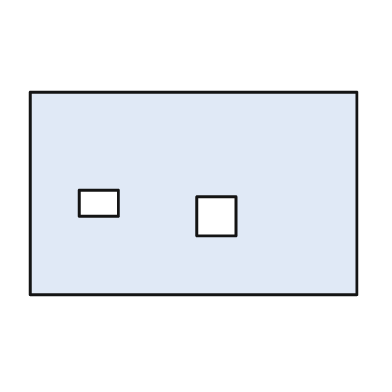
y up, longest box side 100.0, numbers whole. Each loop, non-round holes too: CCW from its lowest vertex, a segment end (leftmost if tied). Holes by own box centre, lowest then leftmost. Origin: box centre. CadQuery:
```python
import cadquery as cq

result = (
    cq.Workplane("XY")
    .moveTo(-50.0, -31.0)
    .lineTo(50.0, -31.0)
    .lineTo(50.0, 31.0)
    .lineTo(-50.0, 31.0)
    .close()
    .moveTo(1.0, -13.0)
    .lineTo(13.0, -13.0)
    .lineTo(13.0, -1.0)
    .lineTo(1.0, -1.0)
    .close()
    .moveTo(-35.0, -7.0)
    .lineTo(-23.0, -7.0)
    .lineTo(-23.0, 1.0)
    .lineTo(-35.0, 1.0)
    .close()
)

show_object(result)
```